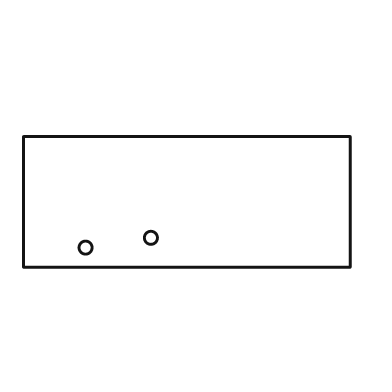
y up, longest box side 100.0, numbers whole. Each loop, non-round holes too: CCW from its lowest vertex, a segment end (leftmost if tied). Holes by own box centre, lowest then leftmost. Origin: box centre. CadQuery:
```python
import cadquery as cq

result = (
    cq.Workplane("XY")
    .moveTo(-50.0, -20.0)
    .lineTo(50.0, -20.0)
    .lineTo(50.0, 20.0)
    .lineTo(-50.0, 20.0)
    .close()
    .moveTo(-31.0, -14.0)
    .circle(2.0)
    .moveTo(-11.0, -11.0)
    .circle(2.0)
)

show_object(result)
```